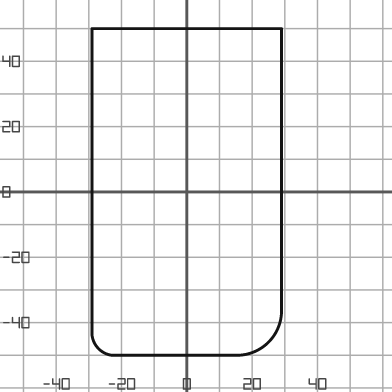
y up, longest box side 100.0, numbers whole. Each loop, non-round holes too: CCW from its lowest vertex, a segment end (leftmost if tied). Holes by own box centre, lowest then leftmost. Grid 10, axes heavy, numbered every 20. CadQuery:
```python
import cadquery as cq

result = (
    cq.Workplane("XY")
    .moveTo(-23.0, -50.0)
    .lineTo(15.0, -50.0)
    .threePointArc((25.0, -46.0), (29.0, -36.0))
    .lineTo(29.0, 50.0)
    .lineTo(-29.0, 50.0)
    .lineTo(-29.0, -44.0)
    .threePointArc((-27.0, -48.0), (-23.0, -50.0))
    .close()
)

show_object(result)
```